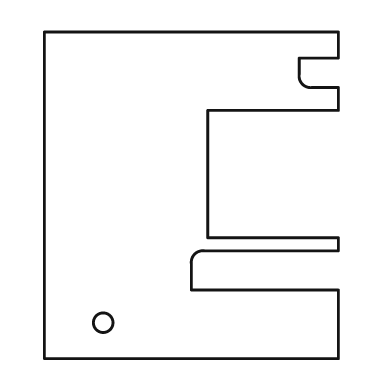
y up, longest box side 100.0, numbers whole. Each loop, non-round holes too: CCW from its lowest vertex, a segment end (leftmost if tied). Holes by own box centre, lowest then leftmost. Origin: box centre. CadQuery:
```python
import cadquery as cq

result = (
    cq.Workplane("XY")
    .moveTo(-45.0, -50.0)
    .lineTo(45.0, -50.0)
    .lineTo(45.0, -29.0)
    .lineTo(0.0, -29.0)
    .lineTo(0.0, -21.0)
    .threePointArc((1.0, -18.0), (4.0, -17.0))
    .lineTo(45.0, -17.0)
    .lineTo(45.0, -13.0)
    .lineTo(5.0, -13.0)
    .lineTo(5.0, 26.0)
    .lineTo(45.0, 26.0)
    .lineTo(45.0, 33.0)
    .lineTo(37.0, 33.0)
    .threePointArc((34.0, 34.0), (33.0, 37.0))
    .lineTo(33.0, 42.0)
    .lineTo(45.0, 42.0)
    .lineTo(45.0, 50.0)
    .lineTo(-45.0, 50.0)
    .close()
    .moveTo(-27.0, -39.0)
    .circle(3.0)
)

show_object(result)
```